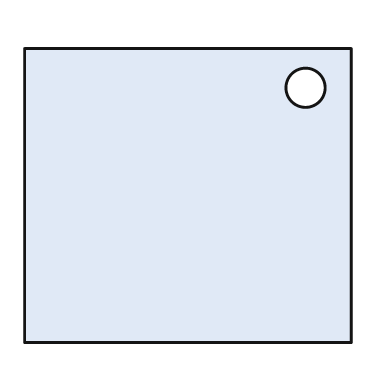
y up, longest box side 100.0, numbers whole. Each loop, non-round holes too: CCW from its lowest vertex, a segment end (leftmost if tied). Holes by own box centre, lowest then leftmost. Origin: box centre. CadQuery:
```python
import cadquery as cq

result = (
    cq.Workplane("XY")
    .moveTo(-50.0, -45.0)
    .lineTo(50.0, -45.0)
    .lineTo(50.0, 45.0)
    .lineTo(-50.0, 45.0)
    .close()
    .moveTo(36.0, 33.0)
    .circle(6.0)
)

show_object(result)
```